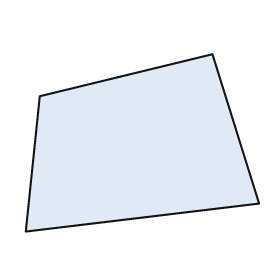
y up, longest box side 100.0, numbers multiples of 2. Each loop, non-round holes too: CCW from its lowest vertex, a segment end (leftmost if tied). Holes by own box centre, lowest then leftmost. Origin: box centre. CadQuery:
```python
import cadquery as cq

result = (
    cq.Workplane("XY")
    .moveTo(-50.0, -38.0)
    .lineTo(50.0, -26.0)
    .lineTo(30.0, 38.0)
    .lineTo(-44.0, 20.0)
    .close()
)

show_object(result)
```